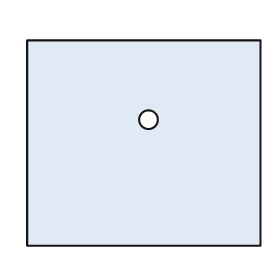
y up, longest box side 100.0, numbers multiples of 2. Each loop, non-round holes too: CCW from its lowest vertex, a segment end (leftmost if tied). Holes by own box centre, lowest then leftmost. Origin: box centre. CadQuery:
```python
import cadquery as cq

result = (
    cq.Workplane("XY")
    .moveTo(-50.0, -44.0)
    .lineTo(50.0, -44.0)
    .lineTo(50.0, 44.0)
    .lineTo(-50.0, 44.0)
    .close()
    .moveTo(2.0, 10.0)
    .circle(4.0)
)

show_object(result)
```